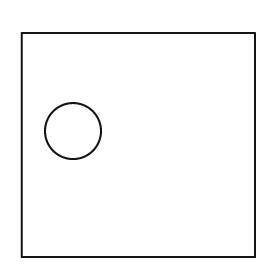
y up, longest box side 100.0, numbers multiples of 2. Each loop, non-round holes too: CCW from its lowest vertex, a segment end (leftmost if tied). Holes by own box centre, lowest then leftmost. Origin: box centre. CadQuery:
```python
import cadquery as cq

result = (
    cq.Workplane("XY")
    .moveTo(-50.0, -48.0)
    .lineTo(50.0, -48.0)
    .lineTo(50.0, 48.0)
    .lineTo(-50.0, 48.0)
    .close()
    .moveTo(-28.0, 6.0)
    .circle(12.0)
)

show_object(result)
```